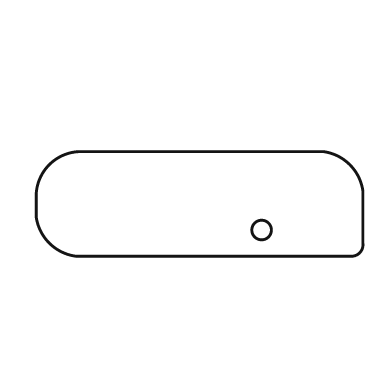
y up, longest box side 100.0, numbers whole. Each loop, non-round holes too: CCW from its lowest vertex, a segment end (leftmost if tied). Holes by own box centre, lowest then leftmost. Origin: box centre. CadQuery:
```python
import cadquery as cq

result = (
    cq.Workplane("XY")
    .moveTo(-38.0, -16.0)
    .lineTo(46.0, -16.0)
    .threePointArc((49.0, -15.0), (50.0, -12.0))
    .lineTo(50.0, 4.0)
    .threePointArc((46.0, 12.0), (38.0, 16.0))
    .lineTo(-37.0, 16.0)
    .threePointArc((-46.0, 12.0), (-50.0, 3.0))
    .lineTo(-50.0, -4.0)
    .threePointArc((-46.0, -12.0), (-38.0, -16.0))
    .close()
    .moveTo(19.0, -8.0)
    .circle(3.0)
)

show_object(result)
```